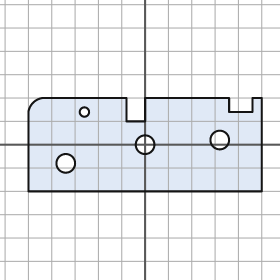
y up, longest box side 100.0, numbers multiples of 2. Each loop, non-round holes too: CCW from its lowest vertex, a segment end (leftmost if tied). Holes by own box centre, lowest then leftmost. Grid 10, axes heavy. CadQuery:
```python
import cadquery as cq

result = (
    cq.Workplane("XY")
    .moveTo(-50.0, -20.0)
    .lineTo(50.0, -20.0)
    .lineTo(50.0, 20.0)
    .lineTo(46.0, 20.0)
    .lineTo(46.0, 14.0)
    .lineTo(36.0, 14.0)
    .lineTo(36.0, 20.0)
    .lineTo(0.0, 20.0)
    .lineTo(0.0, 10.0)
    .lineTo(-8.0, 10.0)
    .lineTo(-8.0, 20.0)
    .lineTo(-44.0, 20.0)
    .threePointArc((-48.0, 18.0), (-50.0, 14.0))
    .close()
    .moveTo(-34.0, -8.0)
    .circle(4.0)
    .moveTo(0.0, 0.0)
    .circle(4.0)
    .moveTo(32.0, 2.0)
    .circle(4.0)
    .moveTo(-26.0, 14.0)
    .circle(2.0)
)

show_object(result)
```